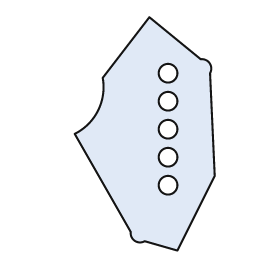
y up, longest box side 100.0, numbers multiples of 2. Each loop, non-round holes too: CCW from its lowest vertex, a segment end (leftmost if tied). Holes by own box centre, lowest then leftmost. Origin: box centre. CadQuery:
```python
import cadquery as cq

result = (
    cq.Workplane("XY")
    .moveTo(14.0, -50.0)
    .lineTo(30.0, -18.0)
    .lineTo(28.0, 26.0)
    .threePointArc((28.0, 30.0), (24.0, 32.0))
    .lineTo(2.0, 50.0)
    .lineTo(-18.0, 24.0)
    .threePointArc((-20.0, 10.0), (-30.0, 0.0))
    .lineTo(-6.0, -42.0)
    .threePointArc((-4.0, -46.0), (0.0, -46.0))
    .close()
    .moveTo(10.0, -22.0)
    .circle(4.0)
    .moveTo(10.0, -10.0)
    .circle(4.0)
    .moveTo(10.0, 2.0)
    .circle(4.0)
    .moveTo(10.0, 14.0)
    .circle(4.0)
    .moveTo(10.0, 26.0)
    .circle(4.0)
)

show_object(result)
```